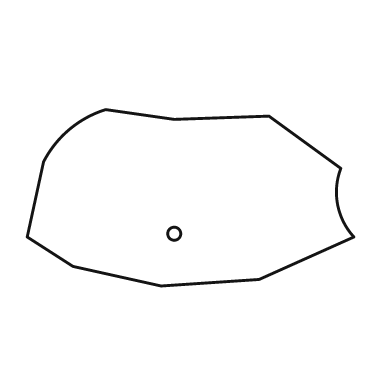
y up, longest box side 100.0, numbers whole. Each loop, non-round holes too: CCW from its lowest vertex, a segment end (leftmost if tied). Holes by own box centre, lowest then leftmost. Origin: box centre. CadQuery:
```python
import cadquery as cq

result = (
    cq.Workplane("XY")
    .moveTo(-9.0, -27.0)
    .lineTo(21.0, -25.0)
    .lineTo(50.0, -12.0)
    .threePointArc((45.0, -2.0), (46.0, 9.0))
    .lineTo(24.0, 25.0)
    .lineTo(-5.0, 24.0)
    .lineTo(-26.0, 27.0)
    .threePointArc((-37.0, 21.0), (-45.0, 11.0))
    .lineTo(-50.0, -12.0)
    .lineTo(-36.0, -21.0)
    .close()
    .moveTo(-5.0, -11.0)
    .circle(2.0)
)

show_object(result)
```